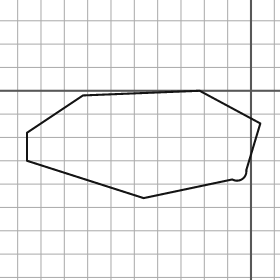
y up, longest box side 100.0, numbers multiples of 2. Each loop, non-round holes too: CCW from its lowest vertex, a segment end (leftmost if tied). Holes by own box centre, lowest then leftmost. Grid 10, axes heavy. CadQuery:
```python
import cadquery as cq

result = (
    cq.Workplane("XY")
    .moveTo(-46.0, -46.0)
    .lineTo(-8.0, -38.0)
    .threePointArc((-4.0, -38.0), (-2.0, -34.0))
    .lineTo(4.0, -14.0)
    .lineTo(-22.0, 0.0)
    .lineTo(-72.0, -2.0)
    .lineTo(-96.0, -18.0)
    .lineTo(-96.0, -30.0)
    .close()
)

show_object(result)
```